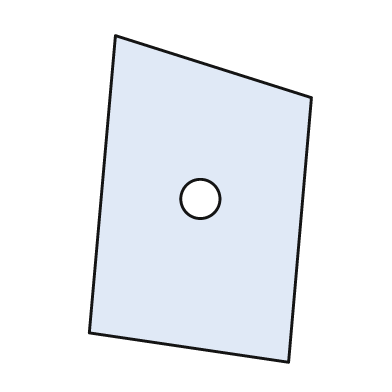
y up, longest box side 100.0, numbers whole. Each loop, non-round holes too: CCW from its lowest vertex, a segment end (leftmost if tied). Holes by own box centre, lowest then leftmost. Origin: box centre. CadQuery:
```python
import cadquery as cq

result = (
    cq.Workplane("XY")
    .moveTo(27.0, -50.0)
    .lineTo(34.0, 31.0)
    .lineTo(-26.0, 50.0)
    .lineTo(-34.0, -41.0)
    .close()
    .moveTo(0.0, 0.0)
    .circle(6.0)
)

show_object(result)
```